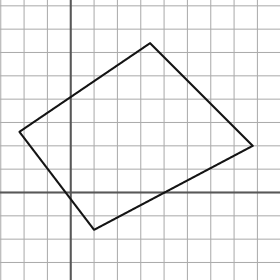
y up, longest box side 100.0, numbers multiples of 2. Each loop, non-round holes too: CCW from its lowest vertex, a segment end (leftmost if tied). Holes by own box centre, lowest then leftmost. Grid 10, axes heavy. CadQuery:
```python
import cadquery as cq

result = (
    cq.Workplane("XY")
    .moveTo(10.0, -16.0)
    .lineTo(78.0, 20.0)
    .lineTo(34.0, 64.0)
    .lineTo(-22.0, 26.0)
    .close()
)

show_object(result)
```